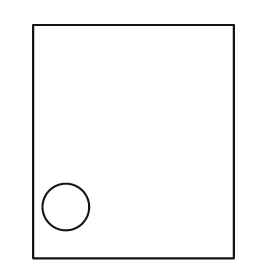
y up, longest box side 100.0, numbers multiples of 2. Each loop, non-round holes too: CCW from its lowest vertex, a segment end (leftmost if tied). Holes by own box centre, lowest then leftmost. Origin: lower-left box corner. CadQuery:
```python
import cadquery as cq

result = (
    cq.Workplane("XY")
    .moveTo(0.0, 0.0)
    .lineTo(86.0, 0.0)
    .lineTo(86.0, 100.0)
    .lineTo(0.0, 100.0)
    .close()
    .moveTo(14.0, 22.0)
    .circle(10.0)
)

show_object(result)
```